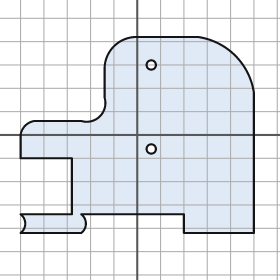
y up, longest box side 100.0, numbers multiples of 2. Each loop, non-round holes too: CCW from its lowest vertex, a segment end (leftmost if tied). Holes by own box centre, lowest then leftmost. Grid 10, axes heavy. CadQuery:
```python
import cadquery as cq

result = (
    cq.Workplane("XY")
    .moveTo(-50.0, -42.0)
    .lineTo(-24.0, -42.0)
    .threePointArc((-22.0, -38.0), (-24.0, -34.0))
    .lineTo(20.0, -34.0)
    .lineTo(20.0, -42.0)
    .lineTo(50.0, -42.0)
    .lineTo(50.0, 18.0)
    .threePointArc((42.0, 34.0), (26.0, 42.0))
    .lineTo(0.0, 42.0)
    .threePointArc((-10.0, 38.0), (-14.0, 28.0))
    .lineTo(-14.0, 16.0)
    .threePointArc((-16.0, 8.0), (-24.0, 6.0))
    .lineTo(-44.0, 6.0)
    .threePointArc((-48.0, 4.0), (-50.0, 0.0))
    .lineTo(-50.0, -10.0)
    .lineTo(-28.0, -10.0)
    .lineTo(-28.0, -34.0)
    .lineTo(-50.0, -34.0)
    .threePointArc((-48.0, -38.0), (-50.0, -42.0))
    .close()
    .moveTo(6.0, -6.0)
    .circle(2.0)
    .moveTo(6.0, 30.0)
    .circle(2.0)
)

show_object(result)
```